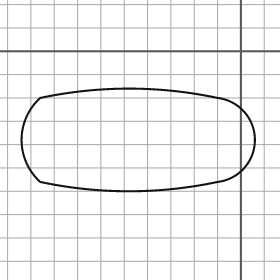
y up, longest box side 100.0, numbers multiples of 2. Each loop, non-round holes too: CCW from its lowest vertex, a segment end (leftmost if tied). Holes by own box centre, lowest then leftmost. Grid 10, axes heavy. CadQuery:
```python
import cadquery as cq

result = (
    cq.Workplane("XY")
    .moveTo(-86.0, -56.0)
    .threePointArc((-48.0, -60.0), (-10.0, -56.0))
    .threePointArc((6.0, -38.0), (-10.0, -20.0))
    .threePointArc((-48.0, -16.0), (-86.0, -20.0))
    .threePointArc((-94.0, -38.0), (-86.0, -56.0))
    .close()
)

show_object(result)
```